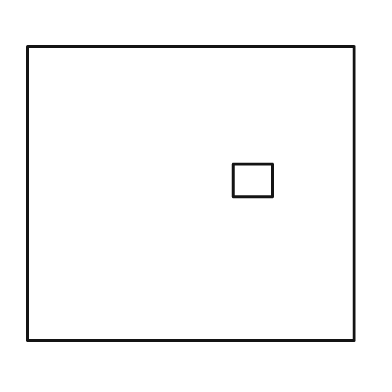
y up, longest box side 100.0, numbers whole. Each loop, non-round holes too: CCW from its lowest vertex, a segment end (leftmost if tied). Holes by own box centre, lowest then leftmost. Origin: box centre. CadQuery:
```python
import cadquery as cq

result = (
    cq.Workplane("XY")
    .moveTo(-50.0, -45.0)
    .lineTo(50.0, -45.0)
    .lineTo(50.0, 45.0)
    .lineTo(-50.0, 45.0)
    .close()
    .moveTo(13.0, -1.0)
    .lineTo(25.0, -1.0)
    .lineTo(25.0, 9.0)
    .lineTo(13.0, 9.0)
    .close()
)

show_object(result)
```